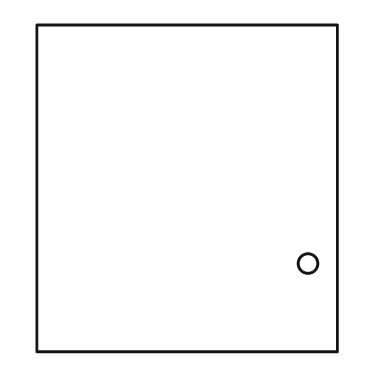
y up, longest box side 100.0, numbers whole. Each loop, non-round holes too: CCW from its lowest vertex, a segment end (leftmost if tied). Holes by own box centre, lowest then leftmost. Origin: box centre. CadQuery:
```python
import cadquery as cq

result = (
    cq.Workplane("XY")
    .moveTo(-46.0, -50.0)
    .lineTo(46.0, -50.0)
    .lineTo(46.0, 50.0)
    .lineTo(-46.0, 50.0)
    .close()
    .moveTo(37.0, -23.0)
    .circle(3.0)
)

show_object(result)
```